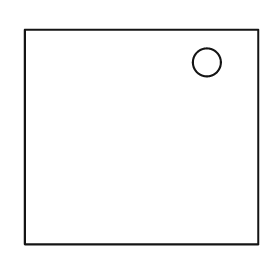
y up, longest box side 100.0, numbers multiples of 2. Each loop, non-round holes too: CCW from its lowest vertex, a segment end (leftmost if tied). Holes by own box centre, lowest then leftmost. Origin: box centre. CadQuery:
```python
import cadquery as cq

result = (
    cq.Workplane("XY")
    .moveTo(-50.0, -46.0)
    .lineTo(50.0, -46.0)
    .lineTo(50.0, 46.0)
    .lineTo(-50.0, 46.0)
    .close()
    .moveTo(28.0, 32.0)
    .circle(6.0)
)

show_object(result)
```